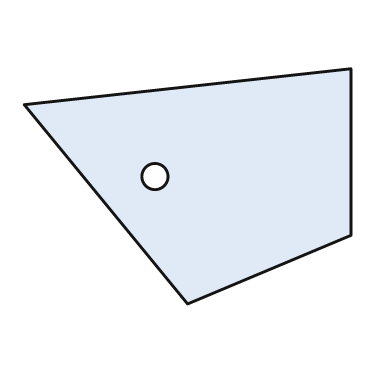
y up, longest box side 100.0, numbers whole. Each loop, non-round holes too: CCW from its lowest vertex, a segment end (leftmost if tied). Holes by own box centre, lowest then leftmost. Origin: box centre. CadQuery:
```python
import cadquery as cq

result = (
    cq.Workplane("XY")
    .moveTo(0.0, -36.0)
    .lineTo(50.0, -15.0)
    .lineTo(50.0, 36.0)
    .lineTo(-50.0, 25.0)
    .close()
    .moveTo(-10.0, 3.0)
    .circle(4.0)
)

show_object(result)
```